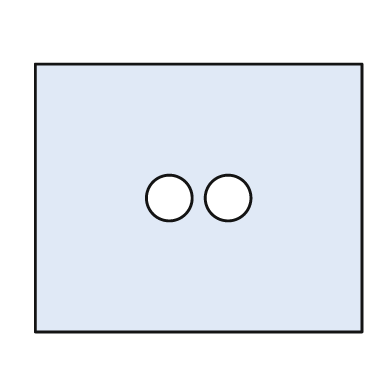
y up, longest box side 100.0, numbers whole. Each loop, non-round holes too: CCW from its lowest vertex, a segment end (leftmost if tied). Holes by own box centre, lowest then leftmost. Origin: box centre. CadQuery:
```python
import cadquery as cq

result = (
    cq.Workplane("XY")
    .moveTo(-50.0, -41.0)
    .lineTo(50.0, -41.0)
    .lineTo(50.0, 41.0)
    .lineTo(-50.0, 41.0)
    .close()
    .moveTo(-9.0, 0.0)
    .circle(7.0)
    .moveTo(9.0, 0.0)
    .circle(7.0)
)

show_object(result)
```